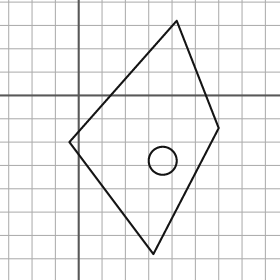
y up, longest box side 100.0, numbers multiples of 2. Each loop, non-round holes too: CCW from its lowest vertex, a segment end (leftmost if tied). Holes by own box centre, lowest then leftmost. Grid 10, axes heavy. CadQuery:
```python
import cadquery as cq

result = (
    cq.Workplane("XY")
    .moveTo(32.0, -68.0)
    .lineTo(60.0, -14.0)
    .lineTo(42.0, 32.0)
    .lineTo(-4.0, -20.0)
    .close()
    .moveTo(36.0, -28.0)
    .circle(6.0)
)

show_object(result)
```